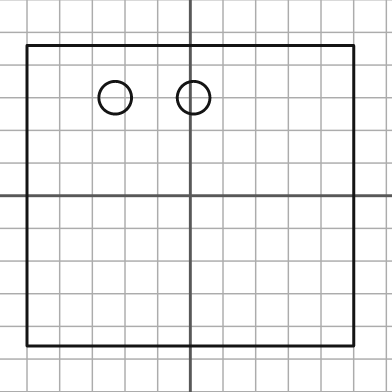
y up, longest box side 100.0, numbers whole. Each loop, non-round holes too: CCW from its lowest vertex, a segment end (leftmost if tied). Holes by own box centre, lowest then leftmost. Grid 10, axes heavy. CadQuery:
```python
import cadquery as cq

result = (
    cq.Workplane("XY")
    .moveTo(-50.0, -46.0)
    .lineTo(50.0, -46.0)
    .lineTo(50.0, 46.0)
    .lineTo(-50.0, 46.0)
    .close()
    .moveTo(-23.0, 30.0)
    .circle(5.0)
    .moveTo(1.0, 30.0)
    .circle(5.0)
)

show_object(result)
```